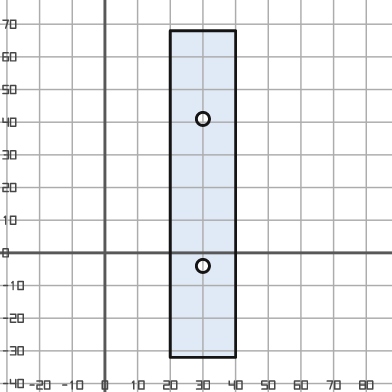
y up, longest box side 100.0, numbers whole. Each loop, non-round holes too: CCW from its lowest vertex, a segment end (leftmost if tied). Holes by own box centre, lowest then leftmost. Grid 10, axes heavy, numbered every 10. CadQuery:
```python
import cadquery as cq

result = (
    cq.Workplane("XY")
    .moveTo(20.0, -32.0)
    .lineTo(40.0, -32.0)
    .lineTo(40.0, 68.0)
    .lineTo(20.0, 68.0)
    .close()
    .moveTo(30.0, -4.0)
    .circle(2.0)
    .moveTo(30.0, 41.0)
    .circle(2.0)
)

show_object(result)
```